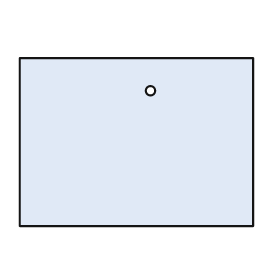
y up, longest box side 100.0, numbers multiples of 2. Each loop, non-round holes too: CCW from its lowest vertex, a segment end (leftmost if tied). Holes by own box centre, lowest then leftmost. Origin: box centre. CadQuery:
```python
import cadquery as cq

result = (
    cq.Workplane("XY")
    .moveTo(-50.0, -36.0)
    .lineTo(50.0, -36.0)
    .lineTo(50.0, 36.0)
    .lineTo(-50.0, 36.0)
    .close()
    .moveTo(6.0, 22.0)
    .circle(2.0)
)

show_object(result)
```